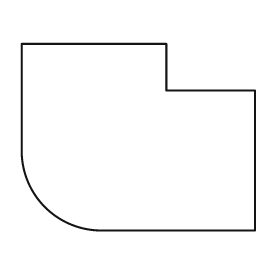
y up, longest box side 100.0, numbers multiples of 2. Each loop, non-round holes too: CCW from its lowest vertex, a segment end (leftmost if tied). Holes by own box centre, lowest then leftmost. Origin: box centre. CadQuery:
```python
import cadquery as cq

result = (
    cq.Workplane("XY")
    .moveTo(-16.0, -40.0)
    .lineTo(50.0, -40.0)
    .lineTo(50.0, 20.0)
    .lineTo(12.0, 20.0)
    .lineTo(12.0, 40.0)
    .lineTo(-50.0, 40.0)
    .lineTo(-50.0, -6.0)
    .threePointArc((-40.0, -30.0), (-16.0, -40.0))
    .close()
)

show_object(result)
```